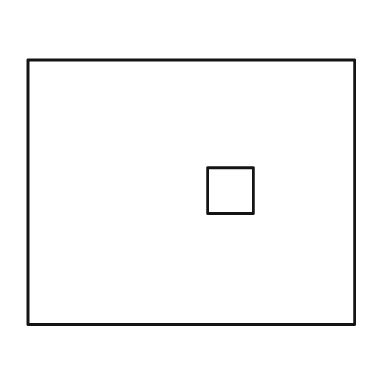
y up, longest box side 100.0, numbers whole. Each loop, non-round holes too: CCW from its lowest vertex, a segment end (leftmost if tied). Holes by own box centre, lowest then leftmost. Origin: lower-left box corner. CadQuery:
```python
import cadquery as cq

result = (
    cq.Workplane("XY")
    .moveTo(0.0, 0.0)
    .lineTo(100.0, 0.0)
    .lineTo(100.0, 81.0)
    .lineTo(0.0, 81.0)
    .close()
    .moveTo(55.0, 34.0)
    .lineTo(69.0, 34.0)
    .lineTo(69.0, 48.0)
    .lineTo(55.0, 48.0)
    .close()
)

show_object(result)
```